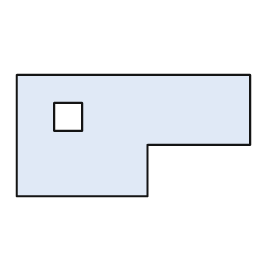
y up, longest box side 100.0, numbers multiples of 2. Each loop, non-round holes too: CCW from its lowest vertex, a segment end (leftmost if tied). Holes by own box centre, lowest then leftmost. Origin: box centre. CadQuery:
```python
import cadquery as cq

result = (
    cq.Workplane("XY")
    .moveTo(-50.0, -26.0)
    .lineTo(6.0, -26.0)
    .lineTo(6.0, -4.0)
    .lineTo(50.0, -4.0)
    .lineTo(50.0, 26.0)
    .lineTo(-50.0, 26.0)
    .close()
    .moveTo(-34.0, 2.0)
    .lineTo(-22.0, 2.0)
    .lineTo(-22.0, 14.0)
    .lineTo(-34.0, 14.0)
    .close()
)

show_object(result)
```